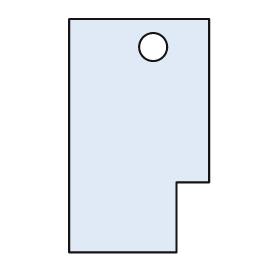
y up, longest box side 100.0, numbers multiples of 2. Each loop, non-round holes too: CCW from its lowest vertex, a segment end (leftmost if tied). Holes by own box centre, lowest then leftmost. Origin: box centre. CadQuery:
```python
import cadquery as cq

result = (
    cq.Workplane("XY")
    .moveTo(-30.0, -50.0)
    .lineTo(16.0, -50.0)
    .lineTo(16.0, -20.0)
    .lineTo(30.0, -20.0)
    .lineTo(30.0, 50.0)
    .lineTo(-30.0, 50.0)
    .close()
    .moveTo(6.0, 38.0)
    .circle(6.0)
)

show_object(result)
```